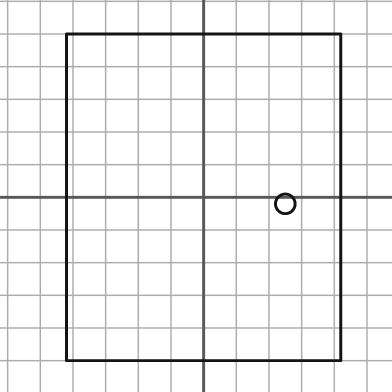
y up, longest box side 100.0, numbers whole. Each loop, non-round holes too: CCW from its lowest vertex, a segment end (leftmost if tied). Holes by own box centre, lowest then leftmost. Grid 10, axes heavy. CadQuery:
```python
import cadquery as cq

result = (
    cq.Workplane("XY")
    .moveTo(-42.0, -50.0)
    .lineTo(42.0, -50.0)
    .lineTo(42.0, 50.0)
    .lineTo(-42.0, 50.0)
    .close()
    .moveTo(25.0, -2.0)
    .circle(3.0)
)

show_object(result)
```